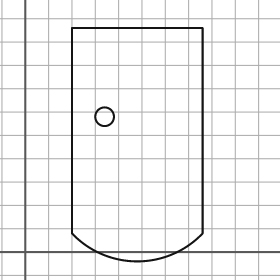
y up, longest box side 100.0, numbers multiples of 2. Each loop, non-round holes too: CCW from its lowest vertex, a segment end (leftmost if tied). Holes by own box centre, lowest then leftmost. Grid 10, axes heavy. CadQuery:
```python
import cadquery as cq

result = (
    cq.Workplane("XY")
    .moveTo(20.0, 8.0)
    .threePointArc((48.0, -4.0), (76.0, 8.0))
    .lineTo(76.0, 96.0)
    .lineTo(20.0, 96.0)
    .close()
    .moveTo(34.0, 58.0)
    .circle(4.0)
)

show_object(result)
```